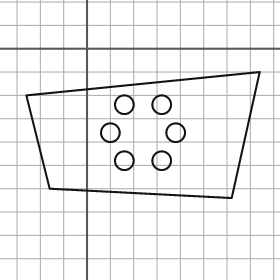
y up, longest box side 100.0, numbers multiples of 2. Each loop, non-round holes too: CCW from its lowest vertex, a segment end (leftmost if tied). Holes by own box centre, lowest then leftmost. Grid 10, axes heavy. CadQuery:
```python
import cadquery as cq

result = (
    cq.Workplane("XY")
    .moveTo(62.0, -64.0)
    .lineTo(74.0, -10.0)
    .lineTo(-26.0, -20.0)
    .lineTo(-16.0, -60.0)
    .close()
    .moveTo(16.0, -48.0)
    .circle(4.0)
    .moveTo(32.0, -48.0)
    .circle(4.0)
    .moveTo(10.0, -36.0)
    .circle(4.0)
    .moveTo(38.0, -36.0)
    .circle(4.0)
    .moveTo(16.0, -24.0)
    .circle(4.0)
    .moveTo(32.0, -24.0)
    .circle(4.0)
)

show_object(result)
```